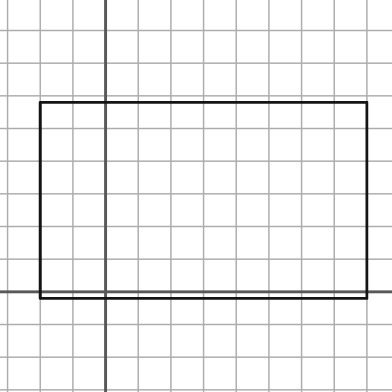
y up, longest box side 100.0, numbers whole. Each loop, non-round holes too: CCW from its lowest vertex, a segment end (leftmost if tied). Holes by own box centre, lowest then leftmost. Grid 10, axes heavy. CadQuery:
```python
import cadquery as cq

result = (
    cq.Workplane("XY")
    .moveTo(-20.0, -2.0)
    .lineTo(80.0, -2.0)
    .lineTo(80.0, 58.0)
    .lineTo(-20.0, 58.0)
    .close()
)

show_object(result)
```